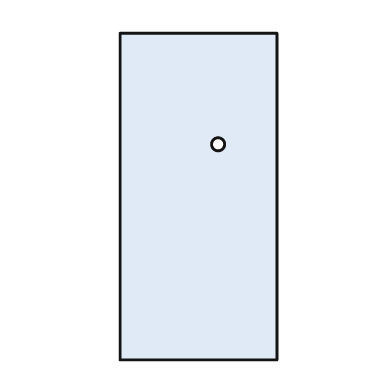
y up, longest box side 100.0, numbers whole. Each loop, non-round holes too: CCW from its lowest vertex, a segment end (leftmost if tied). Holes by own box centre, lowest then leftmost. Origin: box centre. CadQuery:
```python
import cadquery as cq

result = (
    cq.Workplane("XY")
    .moveTo(-24.0, -50.0)
    .lineTo(24.0, -50.0)
    .lineTo(24.0, 50.0)
    .lineTo(-24.0, 50.0)
    .close()
    .moveTo(6.0, 16.0)
    .circle(2.0)
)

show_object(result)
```